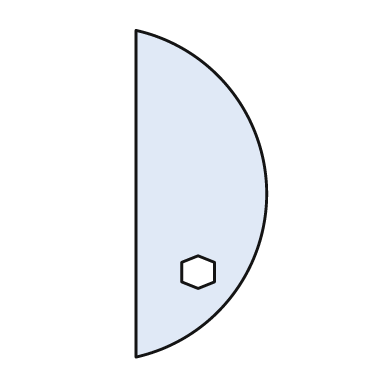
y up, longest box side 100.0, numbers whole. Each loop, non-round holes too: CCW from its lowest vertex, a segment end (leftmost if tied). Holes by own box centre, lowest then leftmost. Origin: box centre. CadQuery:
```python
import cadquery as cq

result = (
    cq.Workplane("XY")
    .moveTo(-20.0, -50.0)
    .threePointArc((20.0, 0.0), (-20.0, 50.0))
    .close()
    .moveTo(-1.0, -29.0)
    .lineTo(4.0, -27.0)
    .lineTo(4.0, -21.0)
    .lineTo(-1.0, -19.0)
    .lineTo(-6.0, -21.0)
    .lineTo(-6.0, -27.0)
    .close()
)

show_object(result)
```